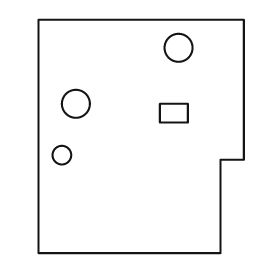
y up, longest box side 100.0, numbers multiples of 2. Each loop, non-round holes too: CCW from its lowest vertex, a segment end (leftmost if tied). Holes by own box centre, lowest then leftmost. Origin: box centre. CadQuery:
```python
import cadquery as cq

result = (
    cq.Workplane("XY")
    .moveTo(-44.0, -50.0)
    .lineTo(34.0, -50.0)
    .lineTo(34.0, -10.0)
    .lineTo(44.0, -10.0)
    .lineTo(44.0, 50.0)
    .lineTo(-44.0, 50.0)
    .close()
    .moveTo(-34.0, -8.0)
    .circle(4.0)
    .moveTo(8.0, 6.0)
    .lineTo(20.0, 6.0)
    .lineTo(20.0, 14.0)
    .lineTo(8.0, 14.0)
    .close()
    .moveTo(-28.0, 14.0)
    .circle(6.0)
    .moveTo(16.0, 38.0)
    .circle(6.0)
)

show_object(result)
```